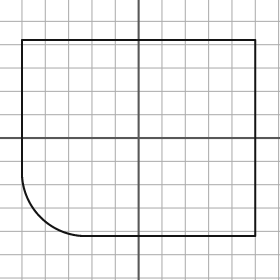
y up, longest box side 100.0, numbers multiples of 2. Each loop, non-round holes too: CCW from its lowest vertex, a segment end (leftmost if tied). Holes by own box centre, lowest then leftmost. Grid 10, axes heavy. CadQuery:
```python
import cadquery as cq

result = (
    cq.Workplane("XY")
    .moveTo(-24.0, -42.0)
    .lineTo(50.0, -42.0)
    .lineTo(50.0, 42.0)
    .lineTo(-50.0, 42.0)
    .lineTo(-50.0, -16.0)
    .threePointArc((-42.0, -34.0), (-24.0, -42.0))
    .close()
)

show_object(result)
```